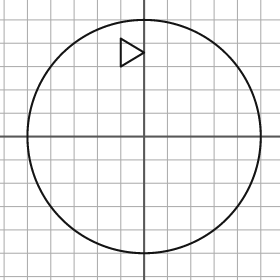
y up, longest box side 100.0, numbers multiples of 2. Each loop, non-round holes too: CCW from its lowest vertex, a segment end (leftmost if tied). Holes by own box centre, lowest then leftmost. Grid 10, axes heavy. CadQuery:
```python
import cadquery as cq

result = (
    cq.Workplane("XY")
    .moveTo(0.0, 0.0)
    .circle(50.0)
    .moveTo(-10.0, 30.0)
    .lineTo(0.0, 36.0)
    .lineTo(-10.0, 42.0)
    .close()
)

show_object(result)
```